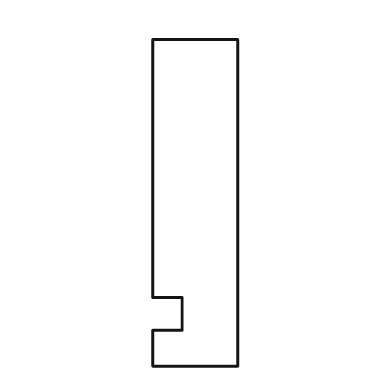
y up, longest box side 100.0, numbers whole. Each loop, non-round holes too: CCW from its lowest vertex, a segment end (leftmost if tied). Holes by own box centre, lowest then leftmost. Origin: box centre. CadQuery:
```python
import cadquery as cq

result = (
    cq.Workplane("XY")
    .moveTo(-13.0, -50.0)
    .lineTo(13.0, -50.0)
    .lineTo(13.0, 50.0)
    .lineTo(-13.0, 50.0)
    .lineTo(-13.0, -29.0)
    .lineTo(-4.0, -29.0)
    .lineTo(-4.0, -39.0)
    .lineTo(-13.0, -39.0)
    .close()
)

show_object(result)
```